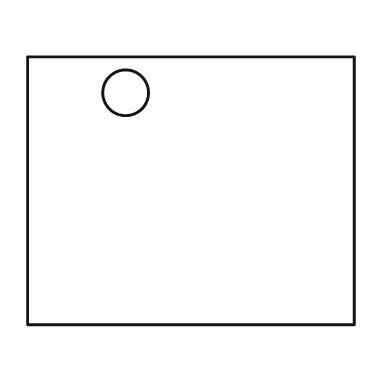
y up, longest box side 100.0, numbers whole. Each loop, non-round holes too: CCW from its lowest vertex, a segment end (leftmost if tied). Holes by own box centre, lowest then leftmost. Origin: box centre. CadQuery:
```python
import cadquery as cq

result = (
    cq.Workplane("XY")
    .moveTo(-50.0, -41.0)
    .lineTo(50.0, -41.0)
    .lineTo(50.0, 41.0)
    .lineTo(-50.0, 41.0)
    .close()
    .moveTo(-20.0, 30.0)
    .circle(7.0)
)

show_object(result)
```